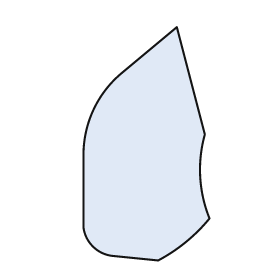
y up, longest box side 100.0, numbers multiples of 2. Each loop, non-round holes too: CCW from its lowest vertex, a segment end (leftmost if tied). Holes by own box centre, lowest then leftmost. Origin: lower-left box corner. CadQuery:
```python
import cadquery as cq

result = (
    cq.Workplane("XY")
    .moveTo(32.0, 0.0)
    .threePointArc((44.0, 8.0), (54.0, 18.0))
    .threePointArc((50.0, 36.0), (52.0, 54.0))
    .lineTo(40.0, 100.0)
    .lineTo(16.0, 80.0)
    .threePointArc((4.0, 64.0), (0.0, 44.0))
    .lineTo(0.0, 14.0)
    .threePointArc((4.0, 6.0), (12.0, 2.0))
    .close()
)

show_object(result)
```